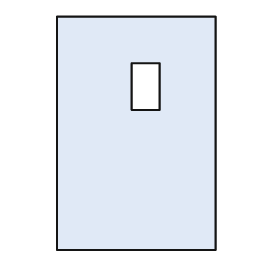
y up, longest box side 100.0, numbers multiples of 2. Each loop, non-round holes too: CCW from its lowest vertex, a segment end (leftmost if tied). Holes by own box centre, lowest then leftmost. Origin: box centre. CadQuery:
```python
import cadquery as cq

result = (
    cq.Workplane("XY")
    .moveTo(-34.0, -50.0)
    .lineTo(34.0, -50.0)
    .lineTo(34.0, 50.0)
    .lineTo(-34.0, 50.0)
    .close()
    .moveTo(-2.0, 10.0)
    .lineTo(10.0, 10.0)
    .lineTo(10.0, 30.0)
    .lineTo(-2.0, 30.0)
    .close()
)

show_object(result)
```